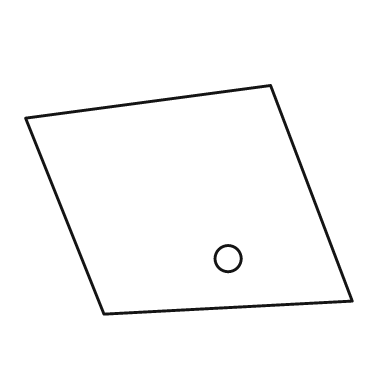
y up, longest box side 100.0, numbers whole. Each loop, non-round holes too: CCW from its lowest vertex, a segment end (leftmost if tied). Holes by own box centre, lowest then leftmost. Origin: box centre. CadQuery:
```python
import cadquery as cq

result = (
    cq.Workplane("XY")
    .moveTo(-26.0, -35.0)
    .lineTo(50.0, -31.0)
    .lineTo(25.0, 35.0)
    .lineTo(-50.0, 25.0)
    .close()
    .moveTo(12.0, -18.0)
    .circle(4.0)
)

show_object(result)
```